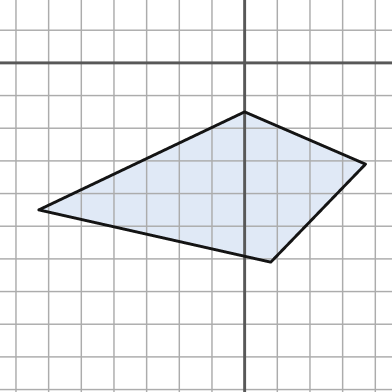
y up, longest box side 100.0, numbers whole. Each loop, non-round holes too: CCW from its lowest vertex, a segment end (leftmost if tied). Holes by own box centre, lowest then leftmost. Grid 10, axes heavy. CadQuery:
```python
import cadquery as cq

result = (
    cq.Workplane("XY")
    .moveTo(8.0, -61.0)
    .lineTo(37.0, -31.0)
    .lineTo(0.0, -15.0)
    .lineTo(-63.0, -45.0)
    .close()
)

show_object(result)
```